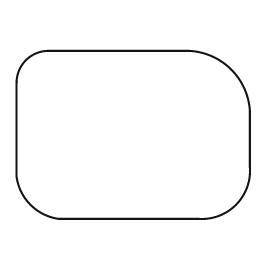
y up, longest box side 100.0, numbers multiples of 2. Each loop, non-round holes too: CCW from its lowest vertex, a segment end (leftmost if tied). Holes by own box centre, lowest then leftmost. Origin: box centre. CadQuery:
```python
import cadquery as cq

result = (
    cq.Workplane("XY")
    .moveTo(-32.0, -36.0)
    .lineTo(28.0, -36.0)
    .threePointArc((44.0, -30.0), (50.0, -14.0))
    .lineTo(50.0, 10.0)
    .threePointArc((42.0, 28.0), (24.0, 36.0))
    .lineTo(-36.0, 36.0)
    .threePointArc((-46.0, 32.0), (-50.0, 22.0))
    .lineTo(-50.0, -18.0)
    .threePointArc((-44.0, -30.0), (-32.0, -36.0))
    .close()
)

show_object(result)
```